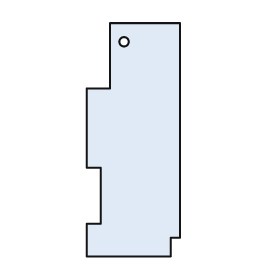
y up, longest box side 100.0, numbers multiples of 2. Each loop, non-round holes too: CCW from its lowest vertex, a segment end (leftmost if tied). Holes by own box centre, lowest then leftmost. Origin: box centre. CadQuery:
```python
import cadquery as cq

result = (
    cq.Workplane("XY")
    .moveTo(-20.0, -50.0)
    .lineTo(16.0, -50.0)
    .lineTo(16.0, -42.0)
    .lineTo(20.0, -42.0)
    .lineTo(20.0, 50.0)
    .lineTo(-10.0, 50.0)
    .lineTo(-10.0, 22.0)
    .lineTo(-20.0, 22.0)
    .lineTo(-20.0, -12.0)
    .lineTo(-14.0, -12.0)
    .lineTo(-14.0, -36.0)
    .lineTo(-20.0, -36.0)
    .close()
    .moveTo(-4.0, 42.0)
    .circle(2.0)
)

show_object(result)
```